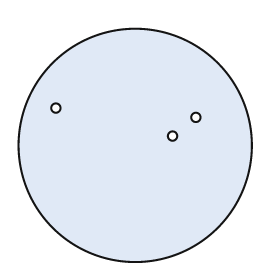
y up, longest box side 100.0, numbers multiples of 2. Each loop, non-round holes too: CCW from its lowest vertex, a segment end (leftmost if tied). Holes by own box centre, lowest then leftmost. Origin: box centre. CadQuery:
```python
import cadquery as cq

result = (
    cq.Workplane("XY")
    .moveTo(0.0, 0.0)
    .circle(50.0)
    .moveTo(16.0, 4.0)
    .circle(2.0)
    .moveTo(26.0, 12.0)
    .circle(2.0)
    .moveTo(-34.0, 16.0)
    .circle(2.0)
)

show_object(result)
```